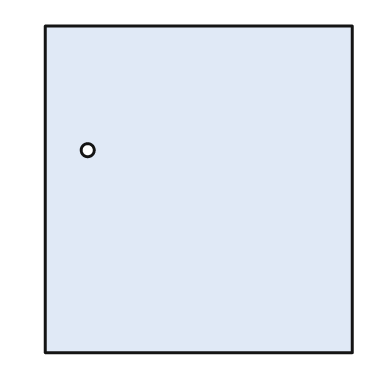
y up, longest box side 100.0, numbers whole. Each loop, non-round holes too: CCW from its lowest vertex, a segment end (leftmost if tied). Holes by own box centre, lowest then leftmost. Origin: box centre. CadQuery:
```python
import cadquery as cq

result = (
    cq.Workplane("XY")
    .moveTo(-47.0, -50.0)
    .lineTo(47.0, -50.0)
    .lineTo(47.0, 50.0)
    .lineTo(-47.0, 50.0)
    .close()
    .moveTo(-34.0, 12.0)
    .circle(2.0)
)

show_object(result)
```